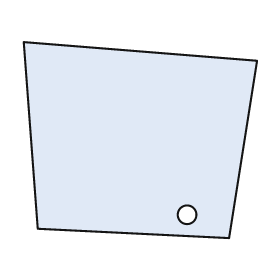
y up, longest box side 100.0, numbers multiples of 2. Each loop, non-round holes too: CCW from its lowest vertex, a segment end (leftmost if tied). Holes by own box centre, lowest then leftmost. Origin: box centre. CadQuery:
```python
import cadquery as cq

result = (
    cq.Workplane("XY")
    .moveTo(38.0, -42.0)
    .lineTo(50.0, 34.0)
    .lineTo(-50.0, 42.0)
    .lineTo(-44.0, -38.0)
    .close()
    .moveTo(20.0, -32.0)
    .circle(4.0)
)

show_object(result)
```